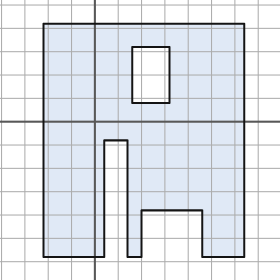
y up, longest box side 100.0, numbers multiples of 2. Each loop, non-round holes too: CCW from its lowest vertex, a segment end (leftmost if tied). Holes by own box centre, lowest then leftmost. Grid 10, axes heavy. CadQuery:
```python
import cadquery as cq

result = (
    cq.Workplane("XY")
    .moveTo(-22.0, -58.0)
    .lineTo(4.0, -58.0)
    .lineTo(4.0, -8.0)
    .lineTo(14.0, -8.0)
    .lineTo(14.0, -58.0)
    .lineTo(20.0, -58.0)
    .lineTo(20.0, -38.0)
    .lineTo(46.0, -38.0)
    .lineTo(46.0, -58.0)
    .lineTo(64.0, -58.0)
    .lineTo(64.0, 42.0)
    .lineTo(-22.0, 42.0)
    .close()
    .moveTo(16.0, 8.0)
    .lineTo(32.0, 8.0)
    .lineTo(32.0, 32.0)
    .lineTo(16.0, 32.0)
    .close()
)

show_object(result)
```